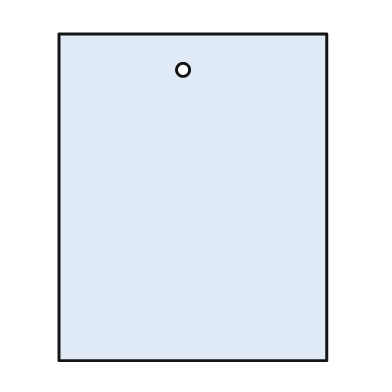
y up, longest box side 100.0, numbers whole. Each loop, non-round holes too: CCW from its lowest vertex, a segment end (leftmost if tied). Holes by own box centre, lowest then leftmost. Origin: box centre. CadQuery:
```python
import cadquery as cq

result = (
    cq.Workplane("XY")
    .moveTo(-41.0, -50.0)
    .lineTo(41.0, -50.0)
    .lineTo(41.0, 50.0)
    .lineTo(-41.0, 50.0)
    .close()
    .moveTo(-3.0, 39.0)
    .circle(2.0)
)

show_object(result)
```